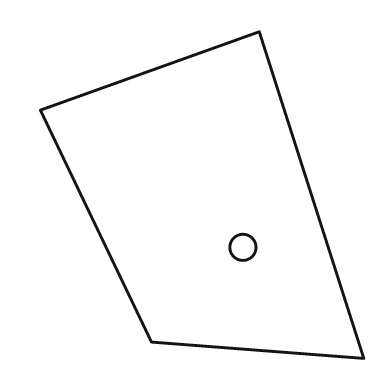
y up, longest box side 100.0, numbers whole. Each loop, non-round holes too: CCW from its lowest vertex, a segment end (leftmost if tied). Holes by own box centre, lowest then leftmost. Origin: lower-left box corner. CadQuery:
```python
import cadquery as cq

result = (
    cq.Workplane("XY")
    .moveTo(99.0, 0.0)
    .lineTo(67.0, 100.0)
    .lineTo(0.0, 76.0)
    .lineTo(34.0, 5.0)
    .close()
    .moveTo(62.0, 34.0)
    .circle(4.0)
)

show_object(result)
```